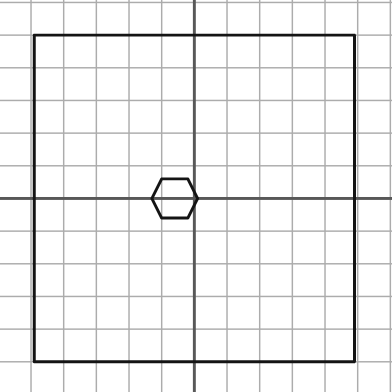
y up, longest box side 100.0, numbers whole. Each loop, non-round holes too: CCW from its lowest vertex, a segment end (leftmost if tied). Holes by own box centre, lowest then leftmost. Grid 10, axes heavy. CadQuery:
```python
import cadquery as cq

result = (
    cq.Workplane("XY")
    .moveTo(-49.0, -50.0)
    .lineTo(49.0, -50.0)
    .lineTo(49.0, 50.0)
    .lineTo(-49.0, 50.0)
    .close()
    .moveTo(-10.0, -6.0)
    .lineTo(-2.0, -6.0)
    .lineTo(1.0, 0.0)
    .lineTo(-2.0, 6.0)
    .lineTo(-10.0, 6.0)
    .lineTo(-13.0, 0.0)
    .close()
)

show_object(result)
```